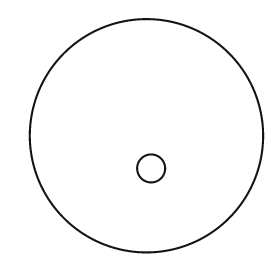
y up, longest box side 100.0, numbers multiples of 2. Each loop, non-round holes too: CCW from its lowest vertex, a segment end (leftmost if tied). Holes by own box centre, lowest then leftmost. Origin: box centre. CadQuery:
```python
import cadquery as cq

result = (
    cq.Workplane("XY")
    .moveTo(0.0, 0.0)
    .circle(50.0)
    .moveTo(2.0, -14.0)
    .circle(6.0)
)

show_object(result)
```